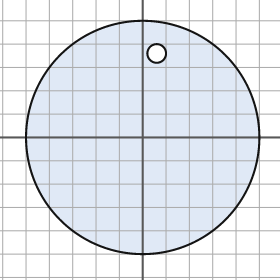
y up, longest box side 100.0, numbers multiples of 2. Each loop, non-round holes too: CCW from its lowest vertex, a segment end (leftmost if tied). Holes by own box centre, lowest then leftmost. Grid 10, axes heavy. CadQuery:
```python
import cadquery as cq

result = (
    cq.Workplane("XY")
    .moveTo(0.0, 0.0)
    .circle(50.0)
    .moveTo(6.0, 36.0)
    .circle(4.0)
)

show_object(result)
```